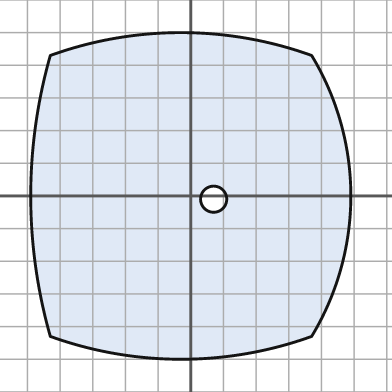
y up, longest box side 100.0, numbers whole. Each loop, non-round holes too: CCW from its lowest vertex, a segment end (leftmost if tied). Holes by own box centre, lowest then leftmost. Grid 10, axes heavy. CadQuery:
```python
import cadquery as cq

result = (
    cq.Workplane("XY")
    .moveTo(-43.0, -43.0)
    .threePointArc((-3.0, -50.0), (37.0, -43.0))
    .threePointArc((49.0, 0.0), (37.0, 43.0))
    .threePointArc((-3.0, 50.0), (-43.0, 43.0))
    .threePointArc((-49.0, 0.0), (-43.0, -43.0))
    .close()
    .moveTo(7.0, -1.0)
    .circle(4.0)
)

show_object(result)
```